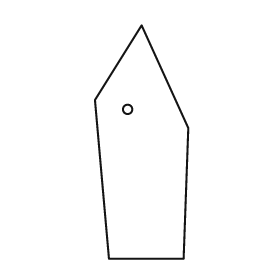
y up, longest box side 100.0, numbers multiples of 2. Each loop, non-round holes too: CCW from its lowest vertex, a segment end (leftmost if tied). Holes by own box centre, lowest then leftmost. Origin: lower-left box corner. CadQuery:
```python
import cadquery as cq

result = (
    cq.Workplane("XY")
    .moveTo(6.0, 0.0)
    .lineTo(38.0, 0.0)
    .lineTo(40.0, 56.0)
    .lineTo(20.0, 100.0)
    .lineTo(0.0, 68.0)
    .close()
    .moveTo(14.0, 64.0)
    .circle(2.0)
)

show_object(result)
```